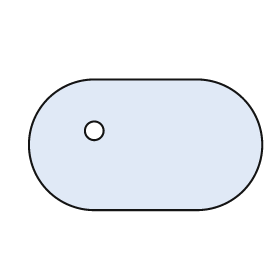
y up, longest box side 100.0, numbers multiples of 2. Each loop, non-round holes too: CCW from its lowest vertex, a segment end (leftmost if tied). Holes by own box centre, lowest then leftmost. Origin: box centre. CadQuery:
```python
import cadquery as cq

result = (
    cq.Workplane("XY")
    .moveTo(-22.0, -28.0)
    .lineTo(22.0, -28.0)
    .threePointArc((50.0, 0.0), (22.0, 28.0))
    .lineTo(-22.0, 28.0)
    .threePointArc((-50.0, 0.0), (-22.0, -28.0))
    .close()
    .moveTo(-22.0, 6.0)
    .circle(4.0)
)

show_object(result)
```